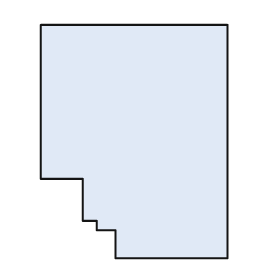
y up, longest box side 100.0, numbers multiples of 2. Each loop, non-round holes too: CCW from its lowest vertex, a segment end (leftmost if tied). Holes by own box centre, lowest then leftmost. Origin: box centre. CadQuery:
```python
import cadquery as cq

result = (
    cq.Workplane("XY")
    .moveTo(-8.0, -50.0)
    .lineTo(40.0, -50.0)
    .lineTo(40.0, 50.0)
    .lineTo(-40.0, 50.0)
    .lineTo(-40.0, -16.0)
    .lineTo(-22.0, -16.0)
    .lineTo(-22.0, -34.0)
    .lineTo(-16.0, -34.0)
    .lineTo(-16.0, -38.0)
    .lineTo(-8.0, -38.0)
    .close()
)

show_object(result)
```